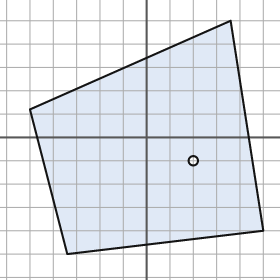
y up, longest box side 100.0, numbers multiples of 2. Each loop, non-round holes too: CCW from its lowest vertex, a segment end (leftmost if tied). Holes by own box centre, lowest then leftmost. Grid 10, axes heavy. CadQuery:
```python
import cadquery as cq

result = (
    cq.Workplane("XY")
    .moveTo(-34.0, -50.0)
    .lineTo(50.0, -40.0)
    .lineTo(36.0, 50.0)
    .lineTo(-50.0, 12.0)
    .close()
    .moveTo(20.0, -10.0)
    .circle(2.0)
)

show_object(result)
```